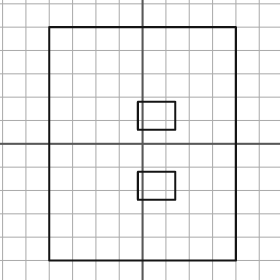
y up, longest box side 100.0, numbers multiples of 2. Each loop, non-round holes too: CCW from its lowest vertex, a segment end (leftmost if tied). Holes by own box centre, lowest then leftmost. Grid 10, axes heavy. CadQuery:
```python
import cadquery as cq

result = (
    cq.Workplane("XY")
    .moveTo(-40.0, -50.0)
    .lineTo(40.0, -50.0)
    .lineTo(40.0, 50.0)
    .lineTo(-40.0, 50.0)
    .close()
    .moveTo(-2.0, -24.0)
    .lineTo(14.0, -24.0)
    .lineTo(14.0, -12.0)
    .lineTo(-2.0, -12.0)
    .close()
    .moveTo(-2.0, 6.0)
    .lineTo(14.0, 6.0)
    .lineTo(14.0, 18.0)
    .lineTo(-2.0, 18.0)
    .close()
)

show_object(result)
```